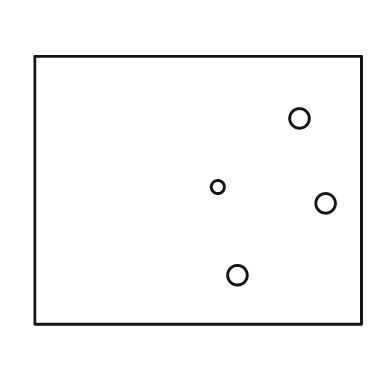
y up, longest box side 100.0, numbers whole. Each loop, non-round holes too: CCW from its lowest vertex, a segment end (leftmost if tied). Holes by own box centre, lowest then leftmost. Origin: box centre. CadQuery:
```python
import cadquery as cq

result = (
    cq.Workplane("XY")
    .moveTo(-50.0, -41.0)
    .lineTo(50.0, -41.0)
    .lineTo(50.0, 41.0)
    .lineTo(-50.0, 41.0)
    .close()
    .moveTo(12.0, -26.0)
    .circle(3.0)
    .moveTo(39.0, -4.0)
    .circle(3.0)
    .moveTo(6.0, 1.0)
    .circle(2.0)
    .moveTo(31.0, 22.0)
    .circle(3.0)
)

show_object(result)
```